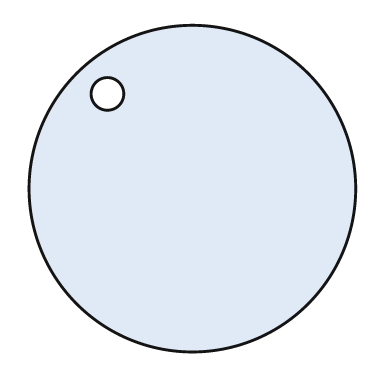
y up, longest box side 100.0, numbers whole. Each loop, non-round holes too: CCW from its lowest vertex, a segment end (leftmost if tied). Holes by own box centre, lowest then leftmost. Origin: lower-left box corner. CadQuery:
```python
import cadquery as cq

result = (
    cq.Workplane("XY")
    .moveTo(50.0, 50.0)
    .circle(50.0)
    .moveTo(24.0, 79.0)
    .circle(5.0)
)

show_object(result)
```